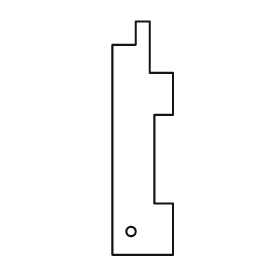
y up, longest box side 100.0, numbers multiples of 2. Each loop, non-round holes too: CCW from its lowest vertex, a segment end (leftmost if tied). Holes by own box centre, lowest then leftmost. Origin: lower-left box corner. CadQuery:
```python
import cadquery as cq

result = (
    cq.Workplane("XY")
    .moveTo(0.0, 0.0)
    .lineTo(26.0, 0.0)
    .lineTo(26.0, 22.0)
    .lineTo(18.0, 22.0)
    .lineTo(18.0, 60.0)
    .lineTo(26.0, 60.0)
    .lineTo(26.0, 78.0)
    .lineTo(16.0, 78.0)
    .lineTo(16.0, 100.0)
    .lineTo(10.0, 100.0)
    .lineTo(10.0, 90.0)
    .lineTo(0.0, 90.0)
    .close()
    .moveTo(8.0, 10.0)
    .circle(2.0)
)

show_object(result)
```